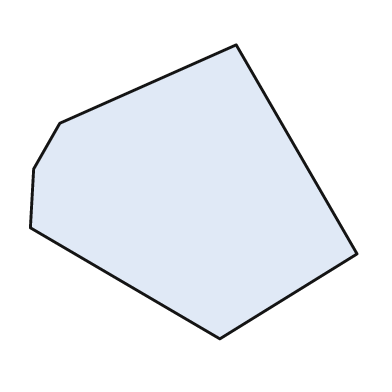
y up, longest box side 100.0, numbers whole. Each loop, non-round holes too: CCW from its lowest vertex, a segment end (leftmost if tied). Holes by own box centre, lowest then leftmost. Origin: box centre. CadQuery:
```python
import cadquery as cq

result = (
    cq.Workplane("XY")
    .moveTo(8.0, -45.0)
    .lineTo(50.0, -19.0)
    .lineTo(13.0, 45.0)
    .lineTo(-41.0, 21.0)
    .lineTo(-49.0, 7.0)
    .lineTo(-50.0, -11.0)
    .close()
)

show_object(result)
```